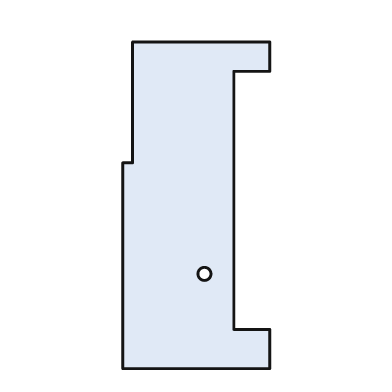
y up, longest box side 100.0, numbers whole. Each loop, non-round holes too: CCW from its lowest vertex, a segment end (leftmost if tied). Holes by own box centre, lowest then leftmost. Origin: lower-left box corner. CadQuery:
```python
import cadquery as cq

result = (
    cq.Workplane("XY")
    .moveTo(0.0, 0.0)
    .lineTo(45.0, 0.0)
    .lineTo(45.0, 12.0)
    .lineTo(34.0, 12.0)
    .lineTo(34.0, 91.0)
    .lineTo(45.0, 91.0)
    .lineTo(45.0, 100.0)
    .lineTo(3.0, 100.0)
    .lineTo(3.0, 63.0)
    .lineTo(0.0, 63.0)
    .close()
    .moveTo(25.0, 29.0)
    .circle(2.0)
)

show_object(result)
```